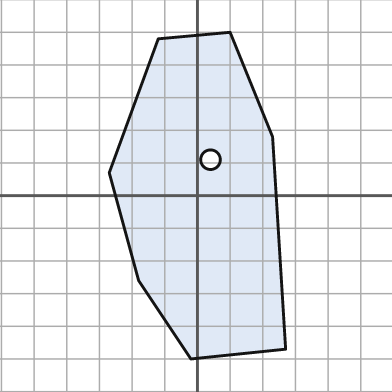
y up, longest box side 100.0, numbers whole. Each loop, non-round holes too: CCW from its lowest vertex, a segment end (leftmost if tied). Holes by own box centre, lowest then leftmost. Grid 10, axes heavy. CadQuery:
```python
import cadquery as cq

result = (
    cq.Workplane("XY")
    .moveTo(-2.0, -50.0)
    .lineTo(27.0, -47.0)
    .lineTo(23.0, 18.0)
    .lineTo(10.0, 50.0)
    .lineTo(-12.0, 48.0)
    .lineTo(-27.0, 7.0)
    .lineTo(-18.0, -26.0)
    .close()
    .moveTo(4.0, 11.0)
    .circle(3.0)
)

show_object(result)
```